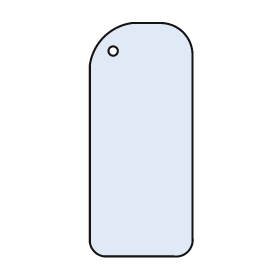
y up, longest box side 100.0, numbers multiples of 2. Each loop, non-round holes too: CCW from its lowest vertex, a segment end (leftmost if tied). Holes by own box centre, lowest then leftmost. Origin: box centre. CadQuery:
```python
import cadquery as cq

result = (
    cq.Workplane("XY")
    .moveTo(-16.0, -50.0)
    .lineTo(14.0, -50.0)
    .threePointArc((20.0, -48.0), (22.0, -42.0))
    .lineTo(22.0, 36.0)
    .threePointArc((18.0, 46.0), (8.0, 50.0))
    .lineTo(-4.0, 50.0)
    .threePointArc((-16.0, 44.0), (-22.0, 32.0))
    .lineTo(-22.0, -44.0)
    .threePointArc((-20.0, -48.0), (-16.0, -50.0))
    .close()
    .moveTo(-12.0, 38.0)
    .circle(2.0)
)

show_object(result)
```